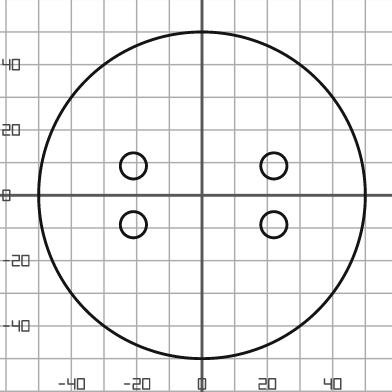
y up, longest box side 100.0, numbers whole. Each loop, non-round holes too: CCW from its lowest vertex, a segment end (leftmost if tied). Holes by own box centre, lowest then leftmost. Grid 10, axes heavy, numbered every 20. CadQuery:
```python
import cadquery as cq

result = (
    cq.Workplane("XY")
    .moveTo(0.0, 0.0)
    .circle(50.0)
    .moveTo(-21.0, -9.0)
    .circle(4.0)
    .moveTo(22.0, -9.0)
    .circle(4.0)
    .moveTo(-21.0, 9.0)
    .circle(4.0)
    .moveTo(22.0, 9.0)
    .circle(4.0)
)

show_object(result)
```